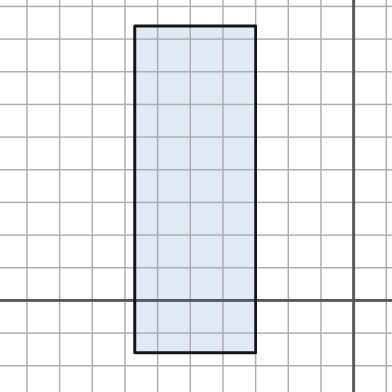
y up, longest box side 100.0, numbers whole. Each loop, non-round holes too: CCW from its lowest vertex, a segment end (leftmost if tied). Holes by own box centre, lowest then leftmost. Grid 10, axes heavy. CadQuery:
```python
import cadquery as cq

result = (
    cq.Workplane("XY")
    .moveTo(-67.0, -16.0)
    .lineTo(-30.0, -16.0)
    .lineTo(-30.0, 84.0)
    .lineTo(-67.0, 84.0)
    .close()
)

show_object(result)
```